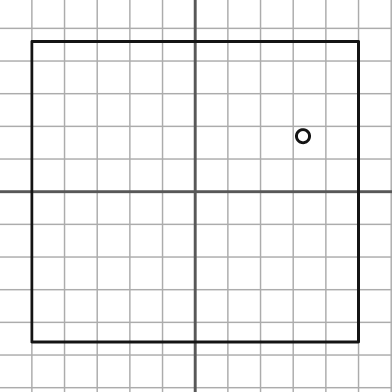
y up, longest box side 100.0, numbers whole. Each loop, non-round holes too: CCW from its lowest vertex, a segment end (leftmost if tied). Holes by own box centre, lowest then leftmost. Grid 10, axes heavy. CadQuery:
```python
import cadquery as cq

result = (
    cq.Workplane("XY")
    .moveTo(-50.0, -46.0)
    .lineTo(50.0, -46.0)
    .lineTo(50.0, 46.0)
    .lineTo(-50.0, 46.0)
    .close()
    .moveTo(33.0, 17.0)
    .circle(2.0)
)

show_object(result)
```